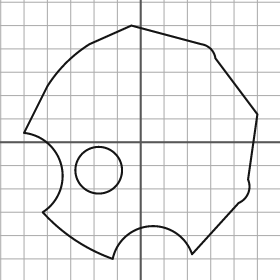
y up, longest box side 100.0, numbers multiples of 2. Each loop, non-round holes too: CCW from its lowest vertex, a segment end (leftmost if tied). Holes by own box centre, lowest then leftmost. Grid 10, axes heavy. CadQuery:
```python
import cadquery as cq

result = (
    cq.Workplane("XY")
    .moveTo(-12.0, -50.0)
    .threePointArc((4.0, -36.0), (22.0, -48.0))
    .lineTo(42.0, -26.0)
    .threePointArc((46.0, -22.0), (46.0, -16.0))
    .lineTo(50.0, 12.0)
    .lineTo(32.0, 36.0)
    .threePointArc((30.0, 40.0), (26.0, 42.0))
    .lineTo(-4.0, 50.0)
    .lineTo(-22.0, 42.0)
    .threePointArc((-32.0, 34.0), (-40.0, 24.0))
    .lineTo(-50.0, 4.0)
    .threePointArc((-34.0, -10.0), (-42.0, -30.0))
    .threePointArc((-28.0, -42.0), (-12.0, -50.0))
    .close()
    .moveTo(-18.0, -12.0)
    .circle(10.0)
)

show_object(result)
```